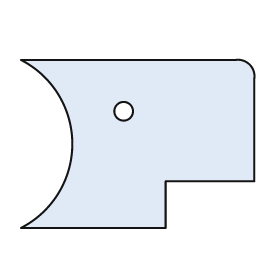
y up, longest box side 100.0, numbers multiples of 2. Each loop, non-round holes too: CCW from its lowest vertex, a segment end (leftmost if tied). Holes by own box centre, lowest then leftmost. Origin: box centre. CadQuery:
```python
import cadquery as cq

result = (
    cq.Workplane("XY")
    .moveTo(-50.0, -36.0)
    .lineTo(12.0, -36.0)
    .lineTo(12.0, -16.0)
    .lineTo(50.0, -16.0)
    .lineTo(50.0, 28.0)
    .threePointArc((48.0, 34.0), (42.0, 36.0))
    .lineTo(-50.0, 36.0)
    .threePointArc((-28.0, 0.0), (-50.0, -36.0))
    .close()
    .moveTo(-6.0, 14.0)
    .circle(4.0)
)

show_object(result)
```